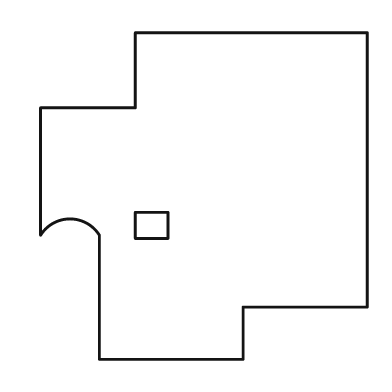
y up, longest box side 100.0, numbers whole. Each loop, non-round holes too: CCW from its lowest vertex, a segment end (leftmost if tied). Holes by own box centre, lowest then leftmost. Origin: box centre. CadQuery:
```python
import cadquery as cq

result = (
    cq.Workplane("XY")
    .moveTo(-32.0, -50.0)
    .lineTo(12.0, -50.0)
    .lineTo(12.0, -34.0)
    .lineTo(50.0, -34.0)
    .lineTo(50.0, 50.0)
    .lineTo(-21.0, 50.0)
    .lineTo(-21.0, 27.0)
    .lineTo(-50.0, 27.0)
    .lineTo(-50.0, -12.0)
    .threePointArc((-41.0, -7.0), (-32.0, -12.0))
    .close()
    .moveTo(-21.0, -13.0)
    .lineTo(-11.0, -13.0)
    .lineTo(-11.0, -5.0)
    .lineTo(-21.0, -5.0)
    .close()
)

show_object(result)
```